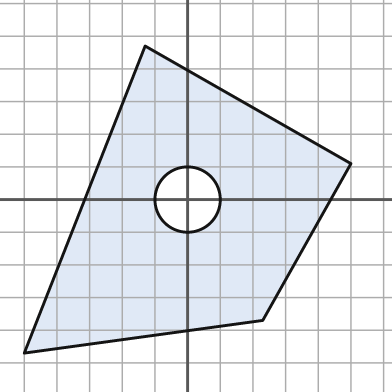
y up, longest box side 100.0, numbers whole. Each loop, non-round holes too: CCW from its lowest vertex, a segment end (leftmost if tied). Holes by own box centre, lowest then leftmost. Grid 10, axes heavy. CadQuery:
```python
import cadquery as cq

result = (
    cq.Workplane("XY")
    .moveTo(-50.0, -47.0)
    .lineTo(23.0, -37.0)
    .lineTo(50.0, 11.0)
    .lineTo(-13.0, 47.0)
    .close()
    .moveTo(0.0, 0.0)
    .circle(10.0)
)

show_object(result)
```